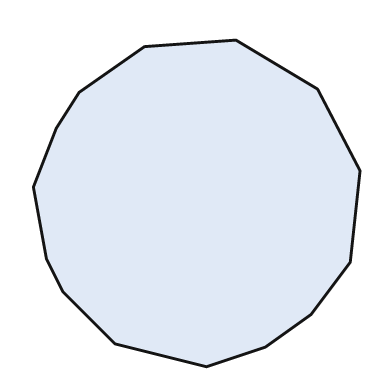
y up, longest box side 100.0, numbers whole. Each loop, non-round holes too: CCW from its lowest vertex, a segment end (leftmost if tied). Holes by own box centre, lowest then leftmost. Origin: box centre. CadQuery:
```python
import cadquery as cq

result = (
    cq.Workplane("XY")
    .moveTo(3.0, -50.0)
    .lineTo(21.0, -44.0)
    .lineTo(35.0, -34.0)
    .lineTo(47.0, -18.0)
    .lineTo(50.0, 10.0)
    .lineTo(37.0, 35.0)
    .lineTo(12.0, 50.0)
    .lineTo(-16.0, 48.0)
    .lineTo(-36.0, 34.0)
    .lineTo(-43.0, 23.0)
    .lineTo(-50.0, 5.0)
    .lineTo(-46.0, -17.0)
    .lineTo(-41.0, -27.0)
    .lineTo(-25.0, -43.0)
    .close()
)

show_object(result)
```